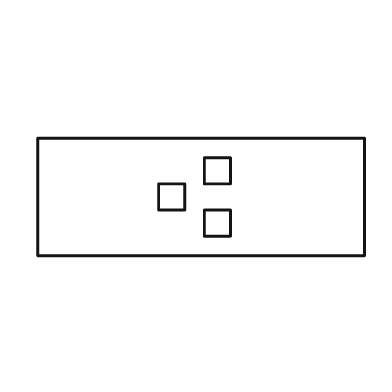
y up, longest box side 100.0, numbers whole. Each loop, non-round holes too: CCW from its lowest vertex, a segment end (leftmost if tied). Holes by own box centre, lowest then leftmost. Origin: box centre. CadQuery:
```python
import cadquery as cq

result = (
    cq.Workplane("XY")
    .moveTo(-50.0, -18.0)
    .lineTo(50.0, -18.0)
    .lineTo(50.0, 18.0)
    .lineTo(-50.0, 18.0)
    .close()
    .moveTo(1.0, -12.0)
    .lineTo(9.0, -12.0)
    .lineTo(9.0, -4.0)
    .lineTo(1.0, -4.0)
    .close()
    .moveTo(-13.0, -4.0)
    .lineTo(-5.0, -4.0)
    .lineTo(-5.0, 4.0)
    .lineTo(-13.0, 4.0)
    .close()
    .moveTo(1.0, 4.0)
    .lineTo(9.0, 4.0)
    .lineTo(9.0, 12.0)
    .lineTo(1.0, 12.0)
    .close()
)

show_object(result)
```